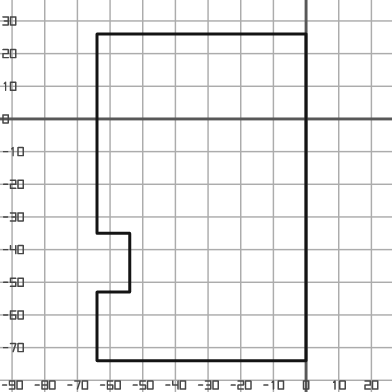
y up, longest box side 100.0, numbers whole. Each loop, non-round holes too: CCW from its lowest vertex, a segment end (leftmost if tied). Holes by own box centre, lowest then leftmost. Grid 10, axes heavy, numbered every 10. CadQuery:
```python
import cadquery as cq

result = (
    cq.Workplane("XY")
    .moveTo(-64.0, -74.0)
    .lineTo(0.0, -74.0)
    .lineTo(0.0, 26.0)
    .lineTo(-64.0, 26.0)
    .lineTo(-64.0, -35.0)
    .lineTo(-54.0, -35.0)
    .lineTo(-54.0, -53.0)
    .lineTo(-64.0, -53.0)
    .close()
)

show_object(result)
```